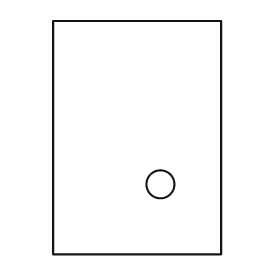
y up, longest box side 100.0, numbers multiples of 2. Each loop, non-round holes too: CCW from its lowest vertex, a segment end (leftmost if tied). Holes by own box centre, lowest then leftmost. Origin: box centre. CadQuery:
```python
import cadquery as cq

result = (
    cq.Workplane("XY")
    .moveTo(-36.0, -50.0)
    .lineTo(36.0, -50.0)
    .lineTo(36.0, 50.0)
    .lineTo(-36.0, 50.0)
    .close()
    .moveTo(10.0, -20.0)
    .circle(6.0)
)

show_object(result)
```